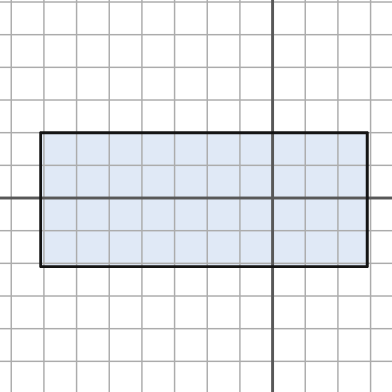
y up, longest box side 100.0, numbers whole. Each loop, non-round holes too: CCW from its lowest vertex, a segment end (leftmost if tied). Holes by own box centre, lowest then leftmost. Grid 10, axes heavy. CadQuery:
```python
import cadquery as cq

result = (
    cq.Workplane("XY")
    .moveTo(-71.0, -21.0)
    .lineTo(29.0, -21.0)
    .lineTo(29.0, 20.0)
    .lineTo(-71.0, 20.0)
    .close()
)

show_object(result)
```